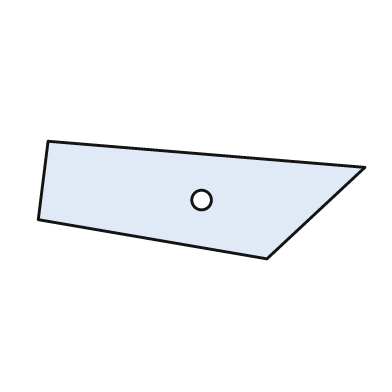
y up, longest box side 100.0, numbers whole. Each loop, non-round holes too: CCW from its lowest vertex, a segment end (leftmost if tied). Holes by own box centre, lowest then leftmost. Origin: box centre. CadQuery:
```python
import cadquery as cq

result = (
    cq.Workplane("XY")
    .moveTo(20.0, -18.0)
    .lineTo(50.0, 10.0)
    .lineTo(-47.0, 18.0)
    .lineTo(-50.0, -6.0)
    .close()
    .moveTo(0.0, 0.0)
    .circle(3.0)
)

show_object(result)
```